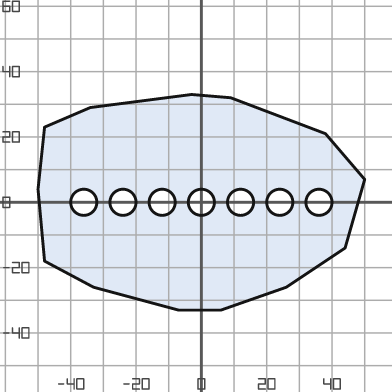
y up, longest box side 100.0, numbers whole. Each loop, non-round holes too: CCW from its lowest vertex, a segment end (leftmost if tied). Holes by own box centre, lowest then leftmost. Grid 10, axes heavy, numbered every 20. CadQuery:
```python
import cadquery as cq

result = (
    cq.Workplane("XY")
    .moveTo(-7.0, -33.0)
    .lineTo(6.0, -33.0)
    .lineTo(26.0, -26.0)
    .lineTo(44.0, -14.0)
    .lineTo(50.0, 7.0)
    .lineTo(38.0, 21.0)
    .lineTo(9.0, 32.0)
    .lineTo(-3.0, 33.0)
    .lineTo(-34.0, 29.0)
    .lineTo(-48.0, 23.0)
    .lineTo(-50.0, 4.0)
    .lineTo(-48.0, -18.0)
    .lineTo(-33.0, -26.0)
    .close()
    .moveTo(-36.0, 0.0)
    .circle(4.0)
    .moveTo(-24.0, 0.0)
    .circle(4.0)
    .moveTo(-12.0, 0.0)
    .circle(4.0)
    .moveTo(0.0, 0.0)
    .circle(4.0)
    .moveTo(12.0, 0.0)
    .circle(4.0)
    .moveTo(24.0, 0.0)
    .circle(4.0)
    .moveTo(36.0, 0.0)
    .circle(4.0)
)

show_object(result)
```